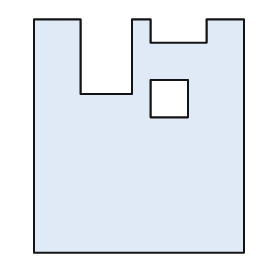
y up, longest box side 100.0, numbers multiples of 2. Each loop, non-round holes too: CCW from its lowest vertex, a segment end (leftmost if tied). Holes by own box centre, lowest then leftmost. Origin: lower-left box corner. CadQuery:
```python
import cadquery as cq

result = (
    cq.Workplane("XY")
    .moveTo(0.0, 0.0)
    .lineTo(90.0, 0.0)
    .lineTo(90.0, 100.0)
    .lineTo(74.0, 100.0)
    .lineTo(74.0, 90.0)
    .lineTo(50.0, 90.0)
    .lineTo(50.0, 100.0)
    .lineTo(42.0, 100.0)
    .lineTo(42.0, 68.0)
    .lineTo(20.0, 68.0)
    .lineTo(20.0, 100.0)
    .lineTo(0.0, 100.0)
    .close()
    .moveTo(50.0, 58.0)
    .lineTo(66.0, 58.0)
    .lineTo(66.0, 74.0)
    .lineTo(50.0, 74.0)
    .close()
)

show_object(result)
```